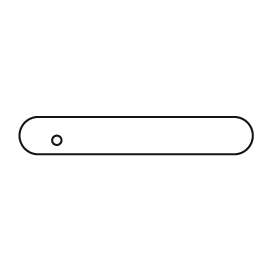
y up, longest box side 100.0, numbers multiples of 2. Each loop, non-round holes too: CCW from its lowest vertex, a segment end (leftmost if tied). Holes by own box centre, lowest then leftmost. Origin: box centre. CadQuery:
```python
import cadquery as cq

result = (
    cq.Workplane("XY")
    .moveTo(-42.0, -8.0)
    .lineTo(42.0, -8.0)
    .threePointArc((50.0, 0.0), (42.0, 8.0))
    .lineTo(-42.0, 8.0)
    .threePointArc((-50.0, 0.0), (-42.0, -8.0))
    .close()
    .moveTo(-34.0, -2.0)
    .circle(2.0)
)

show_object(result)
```